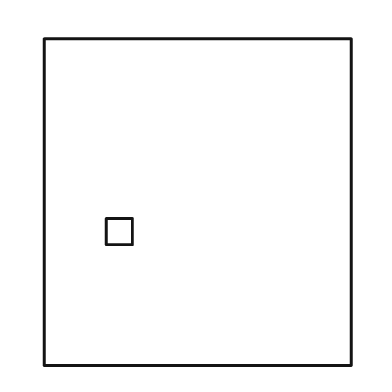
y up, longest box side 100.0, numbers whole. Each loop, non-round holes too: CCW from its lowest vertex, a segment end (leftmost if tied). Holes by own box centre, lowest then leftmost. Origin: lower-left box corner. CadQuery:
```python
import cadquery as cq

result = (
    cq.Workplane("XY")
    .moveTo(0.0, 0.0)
    .lineTo(94.0, 0.0)
    .lineTo(94.0, 100.0)
    .lineTo(0.0, 100.0)
    .close()
    .moveTo(19.0, 37.0)
    .lineTo(27.0, 37.0)
    .lineTo(27.0, 45.0)
    .lineTo(19.0, 45.0)
    .close()
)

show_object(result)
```